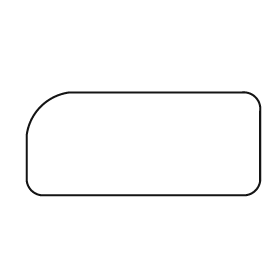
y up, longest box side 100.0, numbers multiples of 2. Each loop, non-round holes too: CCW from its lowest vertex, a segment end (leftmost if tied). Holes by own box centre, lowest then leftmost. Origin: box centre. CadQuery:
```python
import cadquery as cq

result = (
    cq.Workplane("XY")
    .moveTo(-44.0, -22.0)
    .lineTo(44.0, -22.0)
    .threePointArc((48.0, -20.0), (50.0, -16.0))
    .lineTo(50.0, 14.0)
    .threePointArc((48.0, 20.0), (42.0, 22.0))
    .lineTo(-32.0, 22.0)
    .threePointArc((-44.0, 16.0), (-50.0, 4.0))
    .lineTo(-50.0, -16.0)
    .threePointArc((-48.0, -20.0), (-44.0, -22.0))
    .close()
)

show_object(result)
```